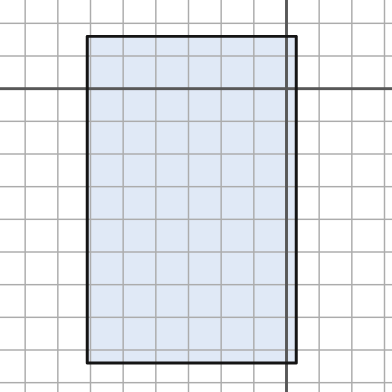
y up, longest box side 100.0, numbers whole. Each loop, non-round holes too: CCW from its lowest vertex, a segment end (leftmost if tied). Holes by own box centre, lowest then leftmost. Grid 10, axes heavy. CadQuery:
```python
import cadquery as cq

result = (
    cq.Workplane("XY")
    .moveTo(-61.0, -84.0)
    .lineTo(3.0, -84.0)
    .lineTo(3.0, 16.0)
    .lineTo(-61.0, 16.0)
    .close()
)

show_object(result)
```